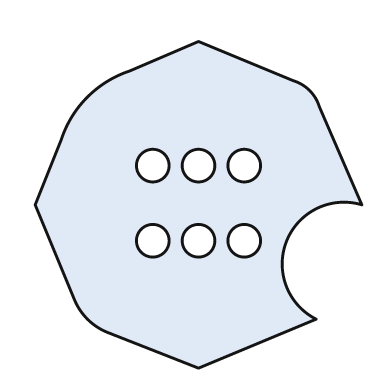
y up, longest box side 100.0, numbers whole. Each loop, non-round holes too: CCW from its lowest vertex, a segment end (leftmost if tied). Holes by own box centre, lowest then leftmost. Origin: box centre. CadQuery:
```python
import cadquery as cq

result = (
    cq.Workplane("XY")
    .moveTo(0.0, -50.0)
    .lineTo(36.0, -35.0)
    .threePointArc((27.0, -11.0), (50.0, 0.0))
    .lineTo(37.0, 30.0)
    .threePointArc((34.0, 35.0), (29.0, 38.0))
    .lineTo(0.0, 50.0)
    .lineTo(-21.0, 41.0)
    .threePointArc((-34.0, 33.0), (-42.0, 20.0))
    .lineTo(-50.0, 0.0)
    .lineTo(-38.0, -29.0)
    .threePointArc((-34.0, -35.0), (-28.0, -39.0))
    .close()
    .moveTo(-14.0, -11.0)
    .circle(5.0)
    .moveTo(0.0, -11.0)
    .circle(5.0)
    .moveTo(14.0, -11.0)
    .circle(5.0)
    .moveTo(-14.0, 12.0)
    .circle(5.0)
    .moveTo(0.0, 12.0)
    .circle(5.0)
    .moveTo(14.0, 12.0)
    .circle(5.0)
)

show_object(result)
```